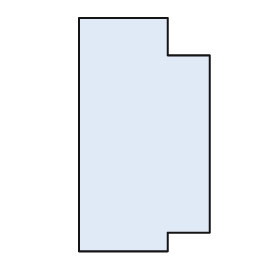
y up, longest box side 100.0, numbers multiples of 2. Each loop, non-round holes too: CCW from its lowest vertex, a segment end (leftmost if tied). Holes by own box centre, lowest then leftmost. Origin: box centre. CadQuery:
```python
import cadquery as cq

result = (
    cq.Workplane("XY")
    .moveTo(-28.0, -50.0)
    .lineTo(10.0, -50.0)
    .lineTo(10.0, -42.0)
    .lineTo(28.0, -42.0)
    .lineTo(28.0, 34.0)
    .lineTo(10.0, 34.0)
    .lineTo(10.0, 50.0)
    .lineTo(-28.0, 50.0)
    .close()
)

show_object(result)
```